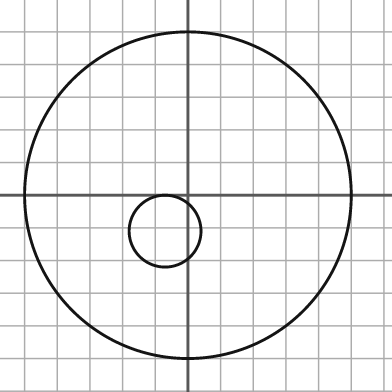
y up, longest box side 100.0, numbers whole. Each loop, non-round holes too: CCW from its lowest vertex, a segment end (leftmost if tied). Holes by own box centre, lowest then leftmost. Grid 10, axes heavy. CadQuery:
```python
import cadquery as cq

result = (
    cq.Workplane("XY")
    .moveTo(0.0, 0.0)
    .circle(50.0)
    .moveTo(-7.0, -11.0)
    .circle(11.0)
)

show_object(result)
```